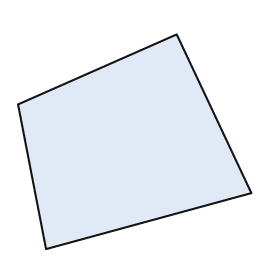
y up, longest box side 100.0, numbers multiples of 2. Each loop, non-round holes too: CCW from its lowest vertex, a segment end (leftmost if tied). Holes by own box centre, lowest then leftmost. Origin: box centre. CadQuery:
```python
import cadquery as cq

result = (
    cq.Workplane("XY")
    .moveTo(-38.0, -46.0)
    .lineTo(50.0, -22.0)
    .lineTo(18.0, 46.0)
    .lineTo(-50.0, 16.0)
    .close()
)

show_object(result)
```